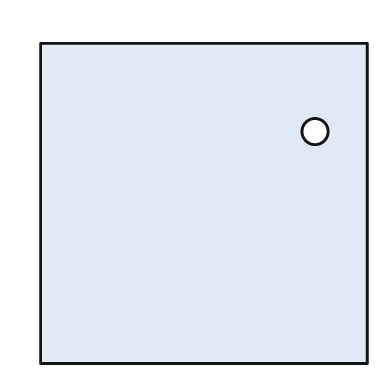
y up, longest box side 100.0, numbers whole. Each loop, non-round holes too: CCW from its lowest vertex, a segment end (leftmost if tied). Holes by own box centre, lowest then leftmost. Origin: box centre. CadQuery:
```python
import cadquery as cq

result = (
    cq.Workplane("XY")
    .moveTo(-50.0, -49.0)
    .lineTo(50.0, -49.0)
    .lineTo(50.0, 49.0)
    .lineTo(-50.0, 49.0)
    .close()
    .moveTo(34.0, 22.0)
    .circle(4.0)
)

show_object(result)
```